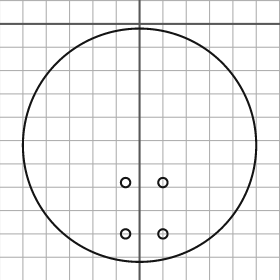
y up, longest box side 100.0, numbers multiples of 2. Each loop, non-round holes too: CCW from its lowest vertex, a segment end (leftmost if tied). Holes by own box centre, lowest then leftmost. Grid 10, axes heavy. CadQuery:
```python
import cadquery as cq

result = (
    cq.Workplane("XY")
    .moveTo(0.0, -52.0)
    .circle(50.0)
    .moveTo(-6.0, -90.0)
    .circle(2.0)
    .moveTo(10.0, -90.0)
    .circle(2.0)
    .moveTo(-6.0, -68.0)
    .circle(2.0)
    .moveTo(10.0, -68.0)
    .circle(2.0)
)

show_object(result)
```